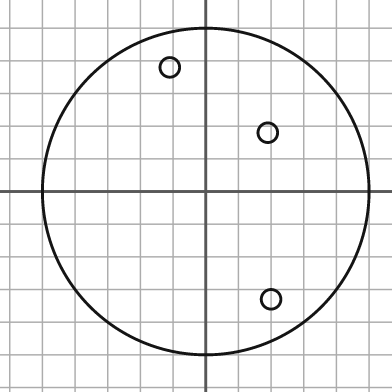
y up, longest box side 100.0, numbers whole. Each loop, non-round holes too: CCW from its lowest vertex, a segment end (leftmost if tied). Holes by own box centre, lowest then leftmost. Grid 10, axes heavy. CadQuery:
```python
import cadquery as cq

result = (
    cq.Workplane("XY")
    .moveTo(0.0, 0.0)
    .circle(50.0)
    .moveTo(20.0, -33.0)
    .circle(3.0)
    .moveTo(19.0, 18.0)
    .circle(3.0)
    .moveTo(-11.0, 38.0)
    .circle(3.0)
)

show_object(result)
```